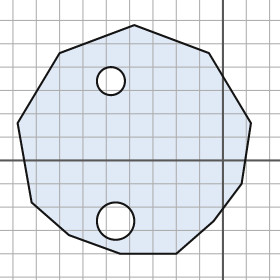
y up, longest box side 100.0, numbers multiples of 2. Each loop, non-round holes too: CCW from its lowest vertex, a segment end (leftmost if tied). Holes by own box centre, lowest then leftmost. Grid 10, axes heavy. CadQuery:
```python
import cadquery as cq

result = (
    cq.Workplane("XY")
    .moveTo(-44.0, -40.0)
    .lineTo(-20.0, -40.0)
    .lineTo(-4.0, -26.0)
    .lineTo(8.0, -10.0)
    .lineTo(12.0, 16.0)
    .lineTo(-6.0, 46.0)
    .lineTo(-38.0, 58.0)
    .lineTo(-70.0, 46.0)
    .lineTo(-88.0, 16.0)
    .lineTo(-82.0, -18.0)
    .lineTo(-66.0, -32.0)
    .close()
    .moveTo(-46.0, -26.0)
    .circle(8.0)
    .moveTo(-48.0, 34.0)
    .circle(6.0)
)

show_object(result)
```